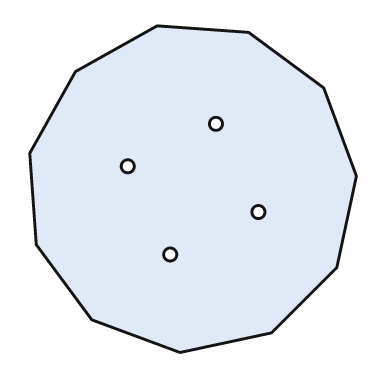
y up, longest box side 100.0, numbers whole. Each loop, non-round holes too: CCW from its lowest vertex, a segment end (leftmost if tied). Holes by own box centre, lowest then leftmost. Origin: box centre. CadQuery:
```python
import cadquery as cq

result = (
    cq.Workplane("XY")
    .moveTo(-4.0, -50.0)
    .lineTo(24.0, -44.0)
    .lineTo(44.0, -24.0)
    .lineTo(50.0, 4.0)
    .lineTo(40.0, 31.0)
    .lineTo(17.0, 48.0)
    .lineTo(-11.0, 50.0)
    .lineTo(-36.0, 36.0)
    .lineTo(-50.0, 11.0)
    .lineTo(-48.0, -17.0)
    .lineTo(-31.0, -40.0)
    .close()
    .moveTo(-7.0, -20.0)
    .circle(2.0)
    .moveTo(20.0, -7.0)
    .circle(2.0)
    .moveTo(-20.0, 7.0)
    .circle(2.0)
    .moveTo(7.0, 20.0)
    .circle(2.0)
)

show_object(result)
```